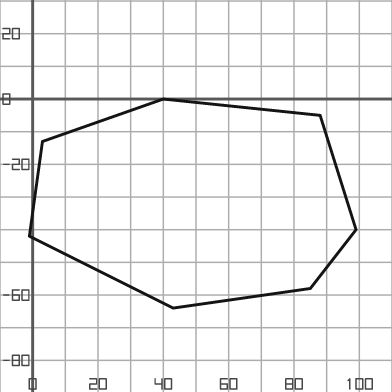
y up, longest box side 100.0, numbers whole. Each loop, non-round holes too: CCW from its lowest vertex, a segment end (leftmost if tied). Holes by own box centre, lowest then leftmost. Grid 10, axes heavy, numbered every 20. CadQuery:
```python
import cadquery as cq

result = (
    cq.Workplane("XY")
    .moveTo(43.0, -64.0)
    .lineTo(85.0, -58.0)
    .lineTo(99.0, -40.0)
    .lineTo(88.0, -5.0)
    .lineTo(40.0, 0.0)
    .lineTo(3.0, -13.0)
    .lineTo(-1.0, -42.0)
    .close()
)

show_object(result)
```